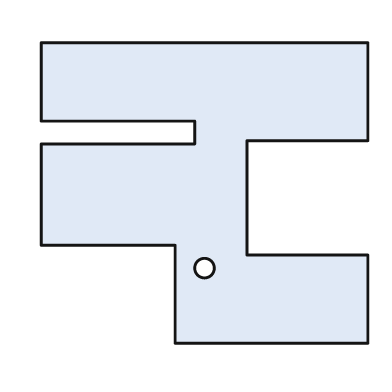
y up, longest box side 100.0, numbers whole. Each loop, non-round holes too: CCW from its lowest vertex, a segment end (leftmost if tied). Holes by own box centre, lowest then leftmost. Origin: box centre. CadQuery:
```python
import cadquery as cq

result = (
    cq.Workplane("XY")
    .moveTo(-9.0, -46.0)
    .lineTo(50.0, -46.0)
    .lineTo(50.0, -19.0)
    .lineTo(13.0, -19.0)
    .lineTo(13.0, 16.0)
    .lineTo(50.0, 16.0)
    .lineTo(50.0, 46.0)
    .lineTo(-50.0, 46.0)
    .lineTo(-50.0, 22.0)
    .lineTo(-3.0, 22.0)
    .lineTo(-3.0, 15.0)
    .lineTo(-50.0, 15.0)
    .lineTo(-50.0, -16.0)
    .lineTo(-9.0, -16.0)
    .close()
    .moveTo(0.0, -23.0)
    .circle(3.0)
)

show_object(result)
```